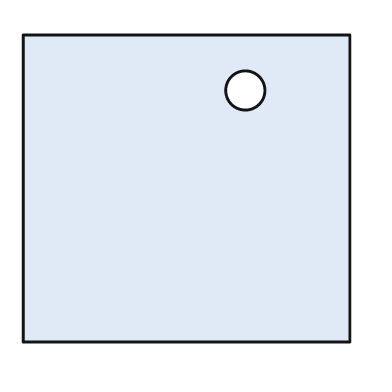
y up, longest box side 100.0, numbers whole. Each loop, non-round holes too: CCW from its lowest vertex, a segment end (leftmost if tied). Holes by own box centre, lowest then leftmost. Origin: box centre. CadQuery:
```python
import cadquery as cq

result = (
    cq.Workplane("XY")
    .moveTo(-50.0, -47.0)
    .lineTo(50.0, -47.0)
    .lineTo(50.0, 47.0)
    .lineTo(-50.0, 47.0)
    .close()
    .moveTo(18.0, 30.0)
    .circle(6.0)
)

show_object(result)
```